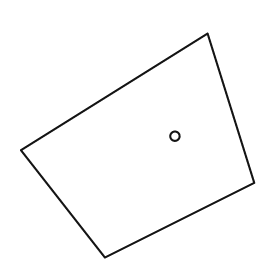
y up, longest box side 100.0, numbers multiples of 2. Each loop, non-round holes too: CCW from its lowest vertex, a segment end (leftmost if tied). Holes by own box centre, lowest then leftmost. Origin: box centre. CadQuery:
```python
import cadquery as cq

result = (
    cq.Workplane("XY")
    .moveTo(-14.0, -48.0)
    .lineTo(50.0, -16.0)
    .lineTo(30.0, 48.0)
    .lineTo(-50.0, -2.0)
    .close()
    .moveTo(16.0, 4.0)
    .circle(2.0)
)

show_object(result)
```